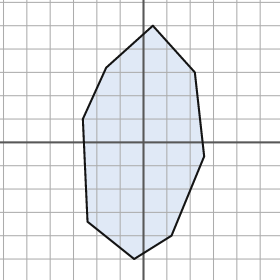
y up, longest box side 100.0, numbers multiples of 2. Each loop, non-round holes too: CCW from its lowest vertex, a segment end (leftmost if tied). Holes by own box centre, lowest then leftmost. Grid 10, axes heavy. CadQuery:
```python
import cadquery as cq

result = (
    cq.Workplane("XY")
    .moveTo(-4.0, -50.0)
    .lineTo(12.0, -40.0)
    .lineTo(26.0, -6.0)
    .lineTo(22.0, 30.0)
    .lineTo(4.0, 50.0)
    .lineTo(-16.0, 32.0)
    .lineTo(-26.0, 10.0)
    .lineTo(-24.0, -34.0)
    .close()
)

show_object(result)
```